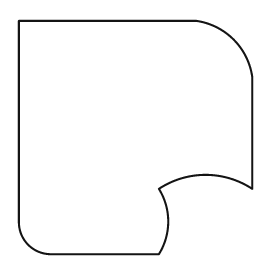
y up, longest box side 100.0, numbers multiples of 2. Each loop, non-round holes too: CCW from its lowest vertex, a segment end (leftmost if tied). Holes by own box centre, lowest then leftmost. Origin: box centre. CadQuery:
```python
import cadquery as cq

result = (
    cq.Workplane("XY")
    .moveTo(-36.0, -50.0)
    .lineTo(10.0, -50.0)
    .threePointArc((14.0, -36.0), (10.0, -22.0))
    .threePointArc((30.0, -16.0), (50.0, -22.0))
    .lineTo(50.0, 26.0)
    .threePointArc((42.0, 42.0), (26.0, 50.0))
    .lineTo(-50.0, 50.0)
    .lineTo(-50.0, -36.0)
    .threePointArc((-46.0, -46.0), (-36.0, -50.0))
    .close()
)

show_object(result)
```